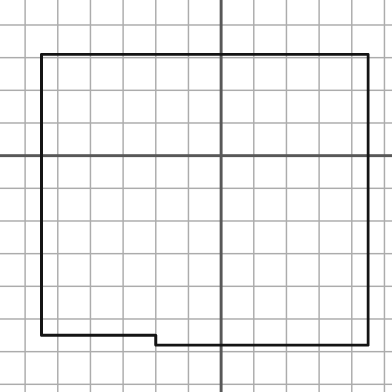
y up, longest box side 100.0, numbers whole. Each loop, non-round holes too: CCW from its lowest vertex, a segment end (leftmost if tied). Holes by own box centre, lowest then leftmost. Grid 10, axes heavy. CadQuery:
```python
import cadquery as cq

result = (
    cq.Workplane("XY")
    .moveTo(-20.0, -58.0)
    .lineTo(45.0, -58.0)
    .lineTo(45.0, 31.0)
    .lineTo(-55.0, 31.0)
    .lineTo(-55.0, -55.0)
    .lineTo(-20.0, -55.0)
    .close()
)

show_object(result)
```